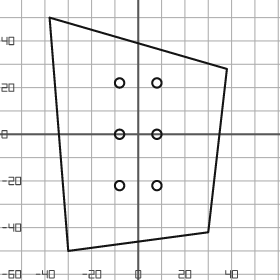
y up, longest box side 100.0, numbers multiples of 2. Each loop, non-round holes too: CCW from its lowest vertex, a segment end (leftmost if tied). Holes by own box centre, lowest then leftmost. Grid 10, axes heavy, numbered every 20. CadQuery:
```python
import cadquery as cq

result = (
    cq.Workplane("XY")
    .moveTo(-30.0, -50.0)
    .lineTo(30.0, -42.0)
    .lineTo(38.0, 28.0)
    .lineTo(-38.0, 50.0)
    .close()
    .moveTo(-8.0, -22.0)
    .circle(2.0)
    .moveTo(8.0, -22.0)
    .circle(2.0)
    .moveTo(-8.0, 0.0)
    .circle(2.0)
    .moveTo(8.0, 0.0)
    .circle(2.0)
    .moveTo(-8.0, 22.0)
    .circle(2.0)
    .moveTo(8.0, 22.0)
    .circle(2.0)
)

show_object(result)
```